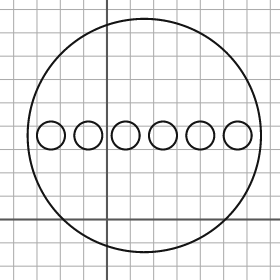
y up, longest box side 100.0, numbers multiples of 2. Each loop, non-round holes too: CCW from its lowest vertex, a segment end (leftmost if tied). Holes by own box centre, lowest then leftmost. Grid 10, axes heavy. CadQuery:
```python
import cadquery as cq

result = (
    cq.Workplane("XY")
    .moveTo(16.0, 36.0)
    .circle(50.0)
    .moveTo(-24.0, 36.0)
    .circle(6.0)
    .moveTo(-8.0, 36.0)
    .circle(6.0)
    .moveTo(8.0, 36.0)
    .circle(6.0)
    .moveTo(24.0, 36.0)
    .circle(6.0)
    .moveTo(40.0, 36.0)
    .circle(6.0)
    .moveTo(56.0, 36.0)
    .circle(6.0)
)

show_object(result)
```